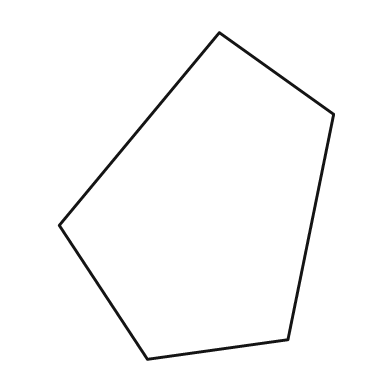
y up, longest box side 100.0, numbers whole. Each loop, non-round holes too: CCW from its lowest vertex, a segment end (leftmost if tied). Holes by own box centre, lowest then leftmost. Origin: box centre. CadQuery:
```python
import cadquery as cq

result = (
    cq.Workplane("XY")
    .moveTo(-15.0, -50.0)
    .lineTo(28.0, -44.0)
    .lineTo(42.0, 25.0)
    .lineTo(7.0, 50.0)
    .lineTo(-42.0, -9.0)
    .close()
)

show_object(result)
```